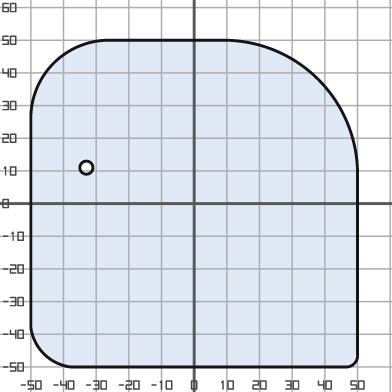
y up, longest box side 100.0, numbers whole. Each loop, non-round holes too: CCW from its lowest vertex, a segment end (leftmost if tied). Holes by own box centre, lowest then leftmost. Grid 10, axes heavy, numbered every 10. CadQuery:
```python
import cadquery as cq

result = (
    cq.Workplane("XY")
    .moveTo(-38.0, -50.0)
    .lineTo(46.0, -50.0)
    .threePointArc((49.0, -49.0), (50.0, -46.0))
    .lineTo(50.0, 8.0)
    .threePointArc((38.0, 38.0), (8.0, 50.0))
    .lineTo(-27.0, 50.0)
    .threePointArc((-43.0, 43.0), (-50.0, 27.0))
    .lineTo(-50.0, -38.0)
    .threePointArc((-46.0, -46.0), (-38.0, -50.0))
    .close()
    .moveTo(-33.0, 11.0)
    .circle(2.0)
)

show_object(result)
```